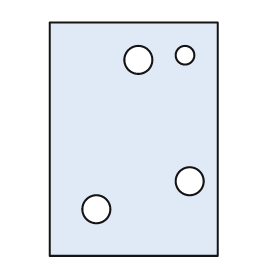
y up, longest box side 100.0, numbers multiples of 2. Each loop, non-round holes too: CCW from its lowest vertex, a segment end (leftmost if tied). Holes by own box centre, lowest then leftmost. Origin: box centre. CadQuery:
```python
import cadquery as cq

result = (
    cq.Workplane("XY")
    .moveTo(-36.0, -50.0)
    .lineTo(36.0, -50.0)
    .lineTo(36.0, 50.0)
    .lineTo(-36.0, 50.0)
    .close()
    .moveTo(-16.0, -30.0)
    .circle(6.0)
    .moveTo(24.0, -18.0)
    .circle(6.0)
    .moveTo(2.0, 34.0)
    .circle(6.0)
    .moveTo(22.0, 36.0)
    .circle(4.0)
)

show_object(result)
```